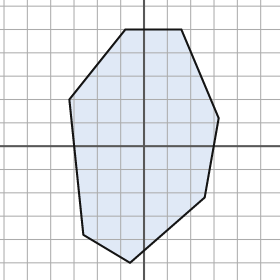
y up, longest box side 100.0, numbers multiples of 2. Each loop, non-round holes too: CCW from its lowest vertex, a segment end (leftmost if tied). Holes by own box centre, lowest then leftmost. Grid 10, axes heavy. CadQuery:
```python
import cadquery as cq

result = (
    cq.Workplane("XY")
    .moveTo(-6.0, -50.0)
    .lineTo(26.0, -22.0)
    .lineTo(32.0, 12.0)
    .lineTo(16.0, 50.0)
    .lineTo(-8.0, 50.0)
    .lineTo(-32.0, 20.0)
    .lineTo(-26.0, -38.0)
    .close()
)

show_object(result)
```